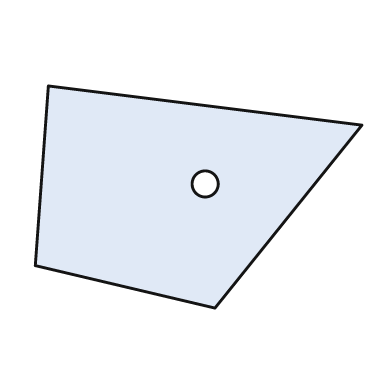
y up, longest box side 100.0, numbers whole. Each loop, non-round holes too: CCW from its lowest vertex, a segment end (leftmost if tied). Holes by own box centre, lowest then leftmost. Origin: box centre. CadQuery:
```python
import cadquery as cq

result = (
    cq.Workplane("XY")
    .moveTo(5.0, -34.0)
    .lineTo(50.0, 22.0)
    .lineTo(-46.0, 34.0)
    .lineTo(-50.0, -21.0)
    .close()
    .moveTo(2.0, 4.0)
    .circle(4.0)
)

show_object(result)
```